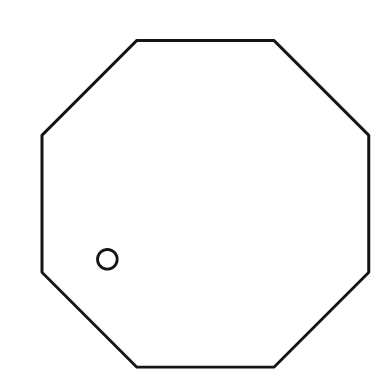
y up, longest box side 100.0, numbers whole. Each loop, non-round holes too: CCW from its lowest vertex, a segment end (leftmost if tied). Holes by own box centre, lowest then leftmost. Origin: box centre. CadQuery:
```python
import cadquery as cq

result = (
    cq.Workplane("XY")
    .moveTo(-21.0, -50.0)
    .lineTo(21.0, -50.0)
    .lineTo(50.0, -21.0)
    .lineTo(50.0, 21.0)
    .lineTo(21.0, 50.0)
    .lineTo(-21.0, 50.0)
    .lineTo(-50.0, 21.0)
    .lineTo(-50.0, -21.0)
    .close()
    .moveTo(-30.0, -17.0)
    .circle(3.0)
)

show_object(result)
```